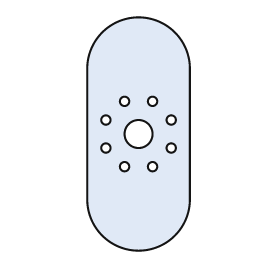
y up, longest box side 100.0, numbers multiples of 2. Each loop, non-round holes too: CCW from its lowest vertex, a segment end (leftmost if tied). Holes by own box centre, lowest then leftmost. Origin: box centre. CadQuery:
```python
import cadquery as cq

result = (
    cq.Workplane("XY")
    .moveTo(-22.0, -28.0)
    .threePointArc((0.0, -50.0), (22.0, -28.0))
    .lineTo(22.0, 28.0)
    .threePointArc((0.0, 50.0), (-22.0, 28.0))
    .close()
    .moveTo(-6.0, -14.0)
    .circle(2.0)
    .moveTo(6.0, -14.0)
    .circle(2.0)
    .moveTo(-14.0, -6.0)
    .circle(2.0)
    .moveTo(14.0, -6.0)
    .circle(2.0)
    .moveTo(0.0, 0.0)
    .circle(6.0)
    .moveTo(-14.0, 6.0)
    .circle(2.0)
    .moveTo(14.0, 6.0)
    .circle(2.0)
    .moveTo(-6.0, 14.0)
    .circle(2.0)
    .moveTo(6.0, 14.0)
    .circle(2.0)
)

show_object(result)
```